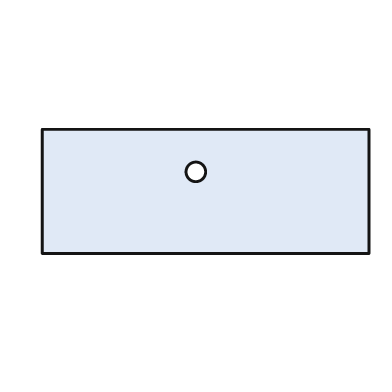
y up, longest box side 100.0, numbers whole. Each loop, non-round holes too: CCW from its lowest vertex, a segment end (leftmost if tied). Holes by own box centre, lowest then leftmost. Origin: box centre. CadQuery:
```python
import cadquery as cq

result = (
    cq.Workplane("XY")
    .moveTo(-50.0, -19.0)
    .lineTo(50.0, -19.0)
    .lineTo(50.0, 19.0)
    .lineTo(-50.0, 19.0)
    .close()
    .moveTo(-3.0, 6.0)
    .circle(3.0)
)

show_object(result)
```